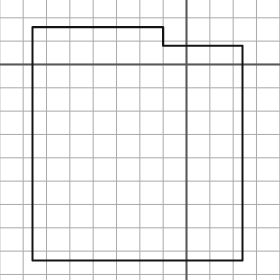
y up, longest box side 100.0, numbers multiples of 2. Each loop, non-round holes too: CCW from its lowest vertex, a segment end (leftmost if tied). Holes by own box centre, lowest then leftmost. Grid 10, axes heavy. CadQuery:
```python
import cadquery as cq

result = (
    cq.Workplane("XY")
    .moveTo(-66.0, -84.0)
    .lineTo(24.0, -84.0)
    .lineTo(24.0, 8.0)
    .lineTo(-10.0, 8.0)
    .lineTo(-10.0, 16.0)
    .lineTo(-66.0, 16.0)
    .close()
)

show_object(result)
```